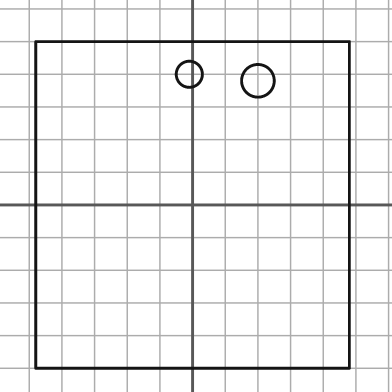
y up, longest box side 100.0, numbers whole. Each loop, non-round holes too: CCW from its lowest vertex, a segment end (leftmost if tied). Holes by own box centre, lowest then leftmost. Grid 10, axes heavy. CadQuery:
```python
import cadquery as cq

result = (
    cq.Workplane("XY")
    .moveTo(-48.0, -50.0)
    .lineTo(48.0, -50.0)
    .lineTo(48.0, 50.0)
    .lineTo(-48.0, 50.0)
    .close()
    .moveTo(20.0, 38.0)
    .circle(5.0)
    .moveTo(-1.0, 40.0)
    .circle(4.0)
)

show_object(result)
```